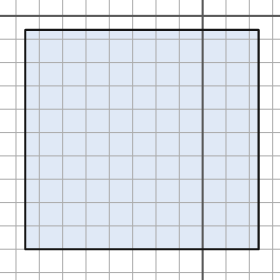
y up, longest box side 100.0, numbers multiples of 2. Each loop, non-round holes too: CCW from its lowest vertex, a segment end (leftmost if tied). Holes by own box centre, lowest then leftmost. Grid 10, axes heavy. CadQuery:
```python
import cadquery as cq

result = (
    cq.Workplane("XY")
    .moveTo(-76.0, -100.0)
    .lineTo(24.0, -100.0)
    .lineTo(24.0, -6.0)
    .lineTo(-76.0, -6.0)
    .close()
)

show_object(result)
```